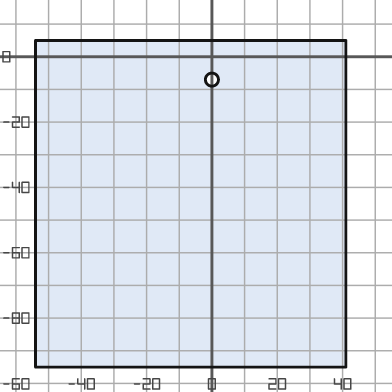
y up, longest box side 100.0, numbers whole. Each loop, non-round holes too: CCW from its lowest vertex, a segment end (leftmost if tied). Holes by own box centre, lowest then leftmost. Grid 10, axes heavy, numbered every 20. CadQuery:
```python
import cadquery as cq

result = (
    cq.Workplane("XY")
    .moveTo(-54.0, -95.0)
    .lineTo(41.0, -95.0)
    .lineTo(41.0, 5.0)
    .lineTo(-54.0, 5.0)
    .close()
    .moveTo(0.0, -7.0)
    .circle(2.0)
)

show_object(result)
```